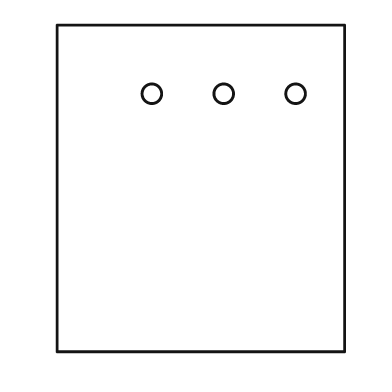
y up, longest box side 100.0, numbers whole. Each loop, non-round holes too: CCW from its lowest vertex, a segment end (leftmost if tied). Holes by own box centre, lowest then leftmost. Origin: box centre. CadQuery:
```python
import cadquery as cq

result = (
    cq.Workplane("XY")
    .moveTo(-44.0, -50.0)
    .lineTo(44.0, -50.0)
    .lineTo(44.0, 50.0)
    .lineTo(-44.0, 50.0)
    .close()
    .moveTo(-15.0, 29.0)
    .circle(3.0)
    .moveTo(7.0, 29.0)
    .circle(3.0)
    .moveTo(29.0, 29.0)
    .circle(3.0)
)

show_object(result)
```